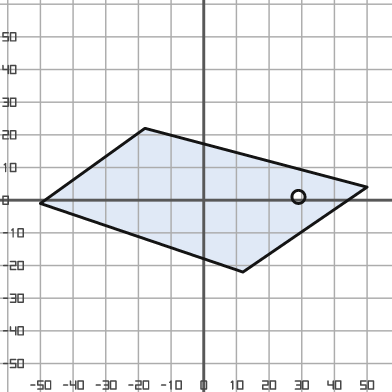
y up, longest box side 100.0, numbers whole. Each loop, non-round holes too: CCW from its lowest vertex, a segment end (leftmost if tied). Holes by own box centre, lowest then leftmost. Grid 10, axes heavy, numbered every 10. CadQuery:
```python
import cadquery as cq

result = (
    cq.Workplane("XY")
    .moveTo(12.0, -22.0)
    .lineTo(50.0, 4.0)
    .lineTo(-18.0, 22.0)
    .lineTo(-50.0, -1.0)
    .close()
    .moveTo(29.0, 1.0)
    .circle(2.0)
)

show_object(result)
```